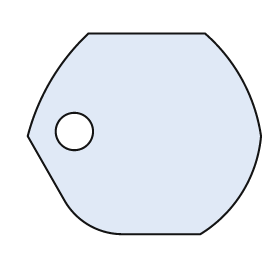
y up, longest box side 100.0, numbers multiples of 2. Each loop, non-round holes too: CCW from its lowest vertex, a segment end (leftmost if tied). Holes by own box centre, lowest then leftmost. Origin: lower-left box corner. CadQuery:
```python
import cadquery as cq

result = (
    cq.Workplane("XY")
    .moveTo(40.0, 0.0)
    .lineTo(74.0, 0.0)
    .threePointArc((92.0, 18.0), (100.0, 42.0))
    .threePointArc((92.0, 66.0), (76.0, 86.0))
    .lineTo(26.0, 86.0)
    .threePointArc((10.0, 66.0), (0.0, 42.0))
    .lineTo(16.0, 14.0)
    .threePointArc((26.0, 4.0), (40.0, 0.0))
    .close()
    .moveTo(20.0, 44.0)
    .circle(8.0)
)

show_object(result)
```